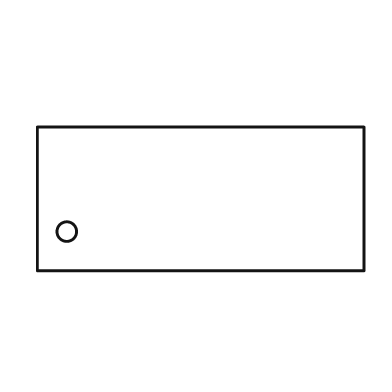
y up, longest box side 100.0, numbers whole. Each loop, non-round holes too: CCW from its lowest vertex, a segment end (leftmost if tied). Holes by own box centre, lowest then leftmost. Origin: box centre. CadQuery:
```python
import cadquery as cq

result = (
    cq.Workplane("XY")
    .moveTo(-50.0, -22.0)
    .lineTo(50.0, -22.0)
    .lineTo(50.0, 22.0)
    .lineTo(-50.0, 22.0)
    .close()
    .moveTo(-41.0, -10.0)
    .circle(3.0)
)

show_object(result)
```